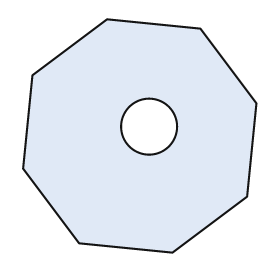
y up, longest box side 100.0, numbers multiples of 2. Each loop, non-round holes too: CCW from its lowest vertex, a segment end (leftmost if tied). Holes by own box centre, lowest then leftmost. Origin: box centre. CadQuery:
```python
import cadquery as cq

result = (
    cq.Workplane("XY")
    .moveTo(14.0, -50.0)
    .lineTo(46.0, -26.0)
    .lineTo(50.0, 14.0)
    .lineTo(26.0, 46.0)
    .lineTo(-14.0, 50.0)
    .lineTo(-46.0, 26.0)
    .lineTo(-50.0, -14.0)
    .lineTo(-26.0, -46.0)
    .close()
    .moveTo(4.0, 4.0)
    .circle(12.0)
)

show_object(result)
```